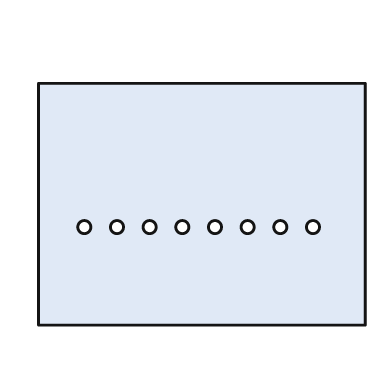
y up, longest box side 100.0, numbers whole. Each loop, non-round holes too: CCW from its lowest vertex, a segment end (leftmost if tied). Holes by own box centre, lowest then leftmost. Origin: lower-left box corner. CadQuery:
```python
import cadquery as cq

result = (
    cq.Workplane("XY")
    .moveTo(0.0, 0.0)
    .lineTo(100.0, 0.0)
    .lineTo(100.0, 74.0)
    .lineTo(0.0, 74.0)
    .close()
    .moveTo(14.0, 30.0)
    .circle(2.0)
    .moveTo(24.0, 30.0)
    .circle(2.0)
    .moveTo(34.0, 30.0)
    .circle(2.0)
    .moveTo(44.0, 30.0)
    .circle(2.0)
    .moveTo(54.0, 30.0)
    .circle(2.0)
    .moveTo(64.0, 30.0)
    .circle(2.0)
    .moveTo(74.0, 30.0)
    .circle(2.0)
    .moveTo(84.0, 30.0)
    .circle(2.0)
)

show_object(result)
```